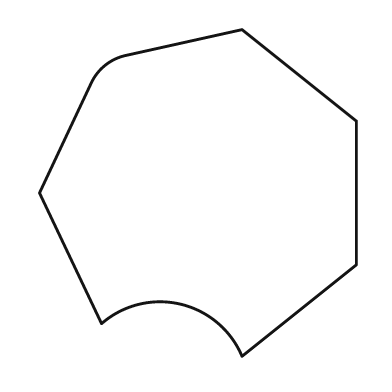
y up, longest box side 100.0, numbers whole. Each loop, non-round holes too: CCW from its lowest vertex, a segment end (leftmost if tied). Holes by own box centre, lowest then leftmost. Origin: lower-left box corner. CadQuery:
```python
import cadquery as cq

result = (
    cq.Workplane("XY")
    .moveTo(62.0, 0.0)
    .lineTo(97.0, 28.0)
    .lineTo(97.0, 72.0)
    .lineTo(62.0, 100.0)
    .lineTo(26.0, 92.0)
    .threePointArc((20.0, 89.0), (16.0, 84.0))
    .lineTo(0.0, 50.0)
    .lineTo(19.0, 10.0)
    .threePointArc((43.0, 16.0), (62.0, 0.0))
    .close()
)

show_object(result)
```